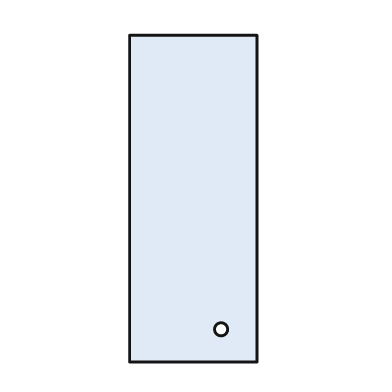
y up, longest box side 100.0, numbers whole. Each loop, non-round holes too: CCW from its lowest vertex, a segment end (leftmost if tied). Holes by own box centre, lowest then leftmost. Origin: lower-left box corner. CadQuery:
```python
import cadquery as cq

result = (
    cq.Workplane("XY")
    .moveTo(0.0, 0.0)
    .lineTo(39.0, 0.0)
    .lineTo(39.0, 100.0)
    .lineTo(0.0, 100.0)
    .close()
    .moveTo(28.0, 10.0)
    .circle(2.0)
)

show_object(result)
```